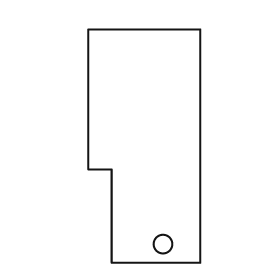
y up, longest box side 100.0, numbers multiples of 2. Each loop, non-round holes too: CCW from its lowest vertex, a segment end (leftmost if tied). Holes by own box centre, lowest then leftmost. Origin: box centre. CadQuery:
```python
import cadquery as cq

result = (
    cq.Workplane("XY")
    .moveTo(-14.0, -50.0)
    .lineTo(24.0, -50.0)
    .lineTo(24.0, 50.0)
    .lineTo(-24.0, 50.0)
    .lineTo(-24.0, -10.0)
    .lineTo(-14.0, -10.0)
    .close()
    .moveTo(8.0, -42.0)
    .circle(4.0)
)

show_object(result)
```